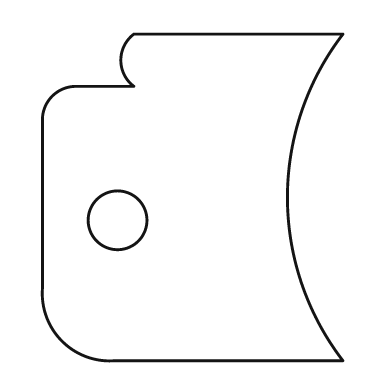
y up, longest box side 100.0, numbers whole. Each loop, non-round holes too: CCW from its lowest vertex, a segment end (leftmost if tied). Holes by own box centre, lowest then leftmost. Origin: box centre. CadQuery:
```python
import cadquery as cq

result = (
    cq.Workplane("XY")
    .moveTo(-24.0, -50.0)
    .lineTo(46.0, -50.0)
    .threePointArc((29.0, 0.0), (46.0, 50.0))
    .lineTo(-18.0, 50.0)
    .threePointArc((-22.0, 42.0), (-18.0, 34.0))
    .lineTo(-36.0, 34.0)
    .threePointArc((-43.0, 31.0), (-46.0, 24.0))
    .lineTo(-46.0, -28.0)
    .threePointArc((-40.0, -44.0), (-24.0, -50.0))
    .close()
    .moveTo(-23.0, -7.0)
    .circle(9.0)
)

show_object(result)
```